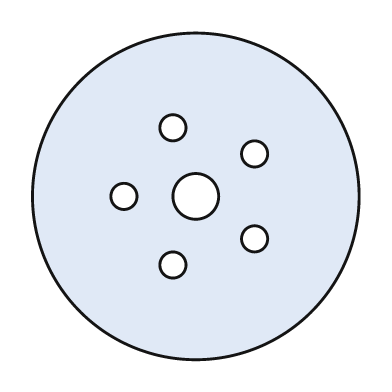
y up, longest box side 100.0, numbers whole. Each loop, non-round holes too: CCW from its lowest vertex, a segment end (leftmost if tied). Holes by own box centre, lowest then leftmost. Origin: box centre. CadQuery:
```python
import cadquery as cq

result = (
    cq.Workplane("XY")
    .moveTo(0.0, 0.0)
    .circle(50.0)
    .moveTo(-7.0, -21.0)
    .circle(4.0)
    .moveTo(18.0, -13.0)
    .circle(4.0)
    .moveTo(-22.0, 0.0)
    .circle(4.0)
    .moveTo(0.0, 0.0)
    .circle(7.0)
    .moveTo(18.0, 13.0)
    .circle(4.0)
    .moveTo(-7.0, 21.0)
    .circle(4.0)
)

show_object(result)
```